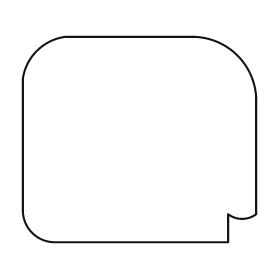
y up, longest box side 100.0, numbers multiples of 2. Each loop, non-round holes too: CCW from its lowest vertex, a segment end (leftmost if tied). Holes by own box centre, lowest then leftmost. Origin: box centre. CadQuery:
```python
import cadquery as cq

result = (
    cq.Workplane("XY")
    .moveTo(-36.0, -44.0)
    .lineTo(38.0, -44.0)
    .lineTo(38.0, -32.0)
    .threePointArc((44.0, -34.0), (50.0, -32.0))
    .lineTo(50.0, 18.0)
    .threePointArc((42.0, 36.0), (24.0, 44.0))
    .lineTo(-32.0, 44.0)
    .threePointArc((-44.0, 38.0), (-50.0, 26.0))
    .lineTo(-50.0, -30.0)
    .threePointArc((-46.0, -40.0), (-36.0, -44.0))
    .close()
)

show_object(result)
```